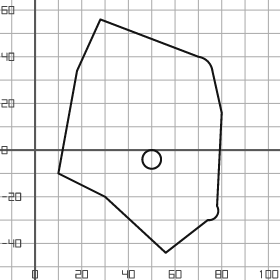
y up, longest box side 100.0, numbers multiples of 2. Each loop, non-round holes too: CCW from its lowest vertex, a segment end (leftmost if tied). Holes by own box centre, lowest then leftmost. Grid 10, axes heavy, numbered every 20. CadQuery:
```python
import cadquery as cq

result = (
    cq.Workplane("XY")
    .moveTo(56.0, -44.0)
    .lineTo(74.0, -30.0)
    .threePointArc((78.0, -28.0), (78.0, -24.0))
    .lineTo(80.0, 16.0)
    .lineTo(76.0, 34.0)
    .threePointArc((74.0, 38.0), (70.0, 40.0))
    .lineTo(28.0, 56.0)
    .lineTo(18.0, 34.0)
    .lineTo(10.0, -10.0)
    .lineTo(30.0, -20.0)
    .close()
    .moveTo(50.0, -4.0)
    .circle(4.0)
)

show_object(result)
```